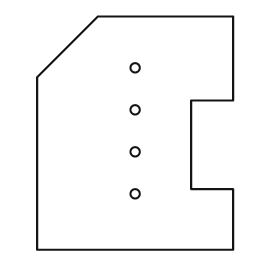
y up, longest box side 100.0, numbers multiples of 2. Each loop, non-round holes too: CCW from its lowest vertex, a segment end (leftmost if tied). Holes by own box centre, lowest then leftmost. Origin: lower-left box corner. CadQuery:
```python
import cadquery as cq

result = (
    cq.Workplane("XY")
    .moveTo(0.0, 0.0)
    .lineTo(84.0, 0.0)
    .lineTo(84.0, 26.0)
    .lineTo(66.0, 26.0)
    .lineTo(66.0, 64.0)
    .lineTo(84.0, 64.0)
    .lineTo(84.0, 100.0)
    .lineTo(26.0, 100.0)
    .lineTo(0.0, 74.0)
    .close()
    .moveTo(42.0, 24.0)
    .circle(2.0)
    .moveTo(42.0, 42.0)
    .circle(2.0)
    .moveTo(42.0, 60.0)
    .circle(2.0)
    .moveTo(42.0, 78.0)
    .circle(2.0)
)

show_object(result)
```